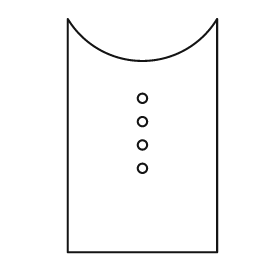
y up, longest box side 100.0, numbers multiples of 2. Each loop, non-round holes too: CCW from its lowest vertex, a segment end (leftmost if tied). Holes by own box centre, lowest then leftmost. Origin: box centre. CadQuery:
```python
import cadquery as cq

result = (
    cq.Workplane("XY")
    .moveTo(-32.0, -50.0)
    .lineTo(32.0, -50.0)
    .lineTo(32.0, 50.0)
    .threePointArc((0.0, 32.0), (-32.0, 50.0))
    .close()
    .moveTo(0.0, -14.0)
    .circle(2.0)
    .moveTo(0.0, -4.0)
    .circle(2.0)
    .moveTo(0.0, 6.0)
    .circle(2.0)
    .moveTo(0.0, 16.0)
    .circle(2.0)
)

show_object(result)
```